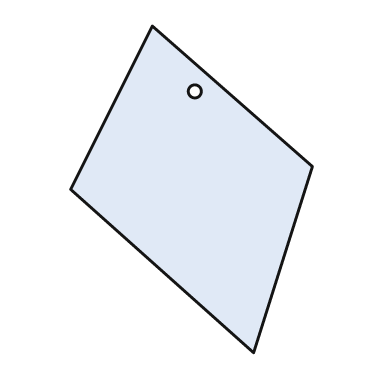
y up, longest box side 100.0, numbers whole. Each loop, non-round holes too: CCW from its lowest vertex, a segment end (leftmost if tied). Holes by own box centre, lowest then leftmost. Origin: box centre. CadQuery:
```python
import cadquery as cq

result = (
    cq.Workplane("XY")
    .moveTo(19.0, -50.0)
    .lineTo(37.0, 7.0)
    .lineTo(-12.0, 50.0)
    .lineTo(-37.0, 0.0)
    .close()
    .moveTo(1.0, 30.0)
    .circle(2.0)
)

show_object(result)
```